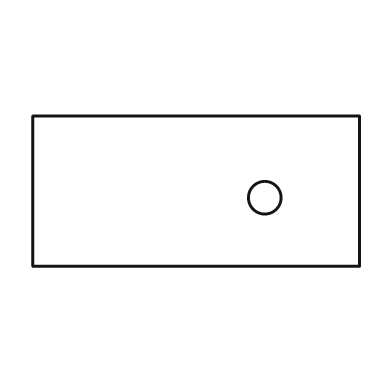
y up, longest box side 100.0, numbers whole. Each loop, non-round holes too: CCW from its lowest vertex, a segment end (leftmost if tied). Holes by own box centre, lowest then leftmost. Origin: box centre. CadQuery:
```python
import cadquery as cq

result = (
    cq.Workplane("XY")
    .moveTo(-50.0, -23.0)
    .lineTo(50.0, -23.0)
    .lineTo(50.0, 23.0)
    .lineTo(-50.0, 23.0)
    .close()
    .moveTo(21.0, -2.0)
    .circle(5.0)
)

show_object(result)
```